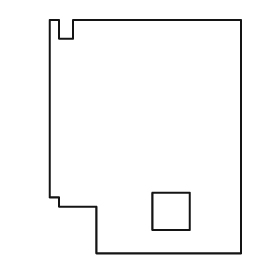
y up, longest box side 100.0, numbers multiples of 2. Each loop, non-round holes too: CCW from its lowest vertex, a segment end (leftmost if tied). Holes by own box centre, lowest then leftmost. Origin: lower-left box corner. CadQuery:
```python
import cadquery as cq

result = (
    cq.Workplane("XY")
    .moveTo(20.0, 0.0)
    .lineTo(82.0, 0.0)
    .lineTo(82.0, 100.0)
    .lineTo(10.0, 100.0)
    .lineTo(10.0, 92.0)
    .lineTo(4.0, 92.0)
    .lineTo(4.0, 100.0)
    .lineTo(0.0, 100.0)
    .lineTo(0.0, 24.0)
    .lineTo(4.0, 24.0)
    .lineTo(4.0, 20.0)
    .lineTo(20.0, 20.0)
    .close()
    .moveTo(44.0, 10.0)
    .lineTo(60.0, 10.0)
    .lineTo(60.0, 26.0)
    .lineTo(44.0, 26.0)
    .close()
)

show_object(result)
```